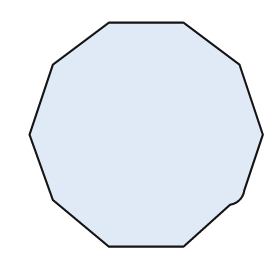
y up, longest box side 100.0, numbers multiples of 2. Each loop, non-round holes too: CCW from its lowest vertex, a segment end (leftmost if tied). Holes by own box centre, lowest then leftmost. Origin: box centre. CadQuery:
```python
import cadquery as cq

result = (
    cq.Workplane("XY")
    .moveTo(-16.0, -48.0)
    .lineTo(16.0, -48.0)
    .lineTo(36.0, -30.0)
    .threePointArc((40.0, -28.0), (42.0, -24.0))
    .lineTo(50.0, 0.0)
    .lineTo(40.0, 30.0)
    .lineTo(16.0, 48.0)
    .lineTo(-16.0, 48.0)
    .lineTo(-40.0, 30.0)
    .lineTo(-50.0, 0.0)
    .lineTo(-40.0, -28.0)
    .close()
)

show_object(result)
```